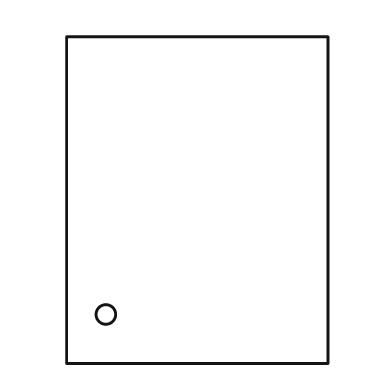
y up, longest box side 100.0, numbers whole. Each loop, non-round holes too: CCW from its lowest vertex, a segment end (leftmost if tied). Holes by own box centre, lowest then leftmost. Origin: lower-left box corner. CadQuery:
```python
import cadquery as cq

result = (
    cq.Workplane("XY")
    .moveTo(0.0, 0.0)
    .lineTo(80.0, 0.0)
    .lineTo(80.0, 100.0)
    .lineTo(0.0, 100.0)
    .close()
    .moveTo(12.0, 15.0)
    .circle(3.0)
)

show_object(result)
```